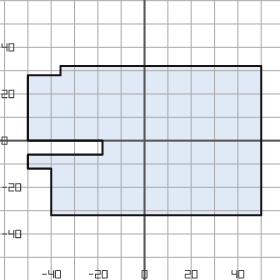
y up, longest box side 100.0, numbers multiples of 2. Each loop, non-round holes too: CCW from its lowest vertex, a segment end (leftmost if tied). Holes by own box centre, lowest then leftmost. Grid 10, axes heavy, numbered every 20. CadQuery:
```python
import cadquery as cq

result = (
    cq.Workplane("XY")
    .moveTo(-40.0, -32.0)
    .lineTo(50.0, -32.0)
    .lineTo(50.0, 32.0)
    .lineTo(-36.0, 32.0)
    .lineTo(-36.0, 28.0)
    .lineTo(-50.0, 28.0)
    .lineTo(-50.0, 0.0)
    .lineTo(-18.0, 0.0)
    .lineTo(-18.0, -6.0)
    .lineTo(-50.0, -6.0)
    .lineTo(-50.0, -12.0)
    .lineTo(-40.0, -12.0)
    .close()
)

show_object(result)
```